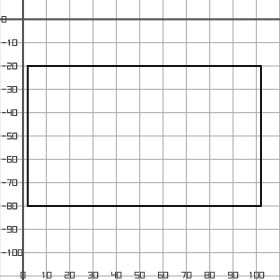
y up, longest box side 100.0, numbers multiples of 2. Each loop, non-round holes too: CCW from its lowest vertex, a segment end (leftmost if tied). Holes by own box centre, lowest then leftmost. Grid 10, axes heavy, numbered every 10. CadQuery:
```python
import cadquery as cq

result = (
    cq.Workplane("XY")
    .moveTo(2.0, -80.0)
    .lineTo(102.0, -80.0)
    .lineTo(102.0, -20.0)
    .lineTo(2.0, -20.0)
    .close()
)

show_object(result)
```